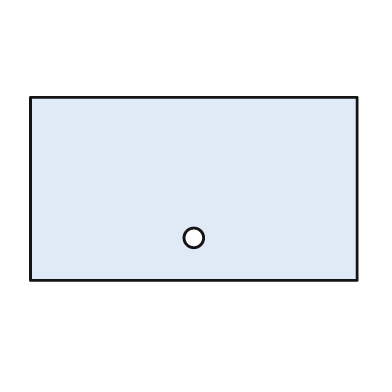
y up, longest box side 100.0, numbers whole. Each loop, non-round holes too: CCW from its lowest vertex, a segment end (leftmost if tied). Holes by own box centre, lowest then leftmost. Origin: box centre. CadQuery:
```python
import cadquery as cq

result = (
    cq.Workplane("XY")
    .moveTo(-50.0, -28.0)
    .lineTo(50.0, -28.0)
    .lineTo(50.0, 28.0)
    .lineTo(-50.0, 28.0)
    .close()
    .moveTo(0.0, -15.0)
    .circle(3.0)
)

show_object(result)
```